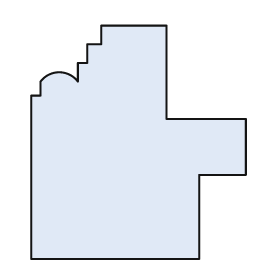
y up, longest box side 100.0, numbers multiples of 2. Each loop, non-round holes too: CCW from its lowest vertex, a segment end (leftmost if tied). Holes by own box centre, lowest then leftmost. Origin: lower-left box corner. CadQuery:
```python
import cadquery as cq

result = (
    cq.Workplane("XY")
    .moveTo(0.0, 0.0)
    .lineTo(72.0, 0.0)
    .lineTo(72.0, 36.0)
    .lineTo(92.0, 36.0)
    .lineTo(92.0, 60.0)
    .lineTo(58.0, 60.0)
    .lineTo(58.0, 100.0)
    .lineTo(30.0, 100.0)
    .lineTo(30.0, 92.0)
    .lineTo(24.0, 92.0)
    .lineTo(24.0, 84.0)
    .lineTo(20.0, 84.0)
    .lineTo(20.0, 76.0)
    .threePointArc((12.0, 80.0), (4.0, 76.0))
    .lineTo(4.0, 70.0)
    .lineTo(0.0, 70.0)
    .close()
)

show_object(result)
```